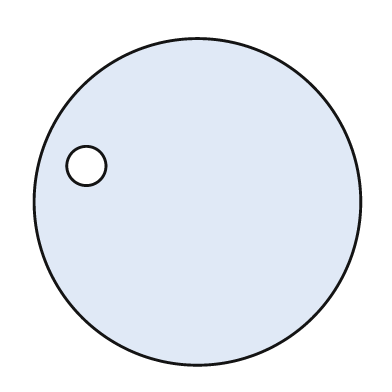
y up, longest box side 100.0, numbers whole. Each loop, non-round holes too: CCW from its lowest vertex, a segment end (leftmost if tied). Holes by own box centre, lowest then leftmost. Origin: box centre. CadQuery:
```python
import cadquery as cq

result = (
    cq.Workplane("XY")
    .moveTo(0.0, 0.0)
    .circle(50.0)
    .moveTo(-34.0, 11.0)
    .circle(6.0)
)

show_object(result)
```